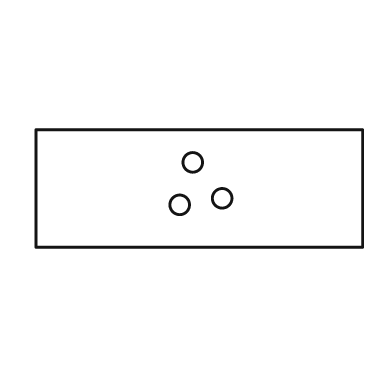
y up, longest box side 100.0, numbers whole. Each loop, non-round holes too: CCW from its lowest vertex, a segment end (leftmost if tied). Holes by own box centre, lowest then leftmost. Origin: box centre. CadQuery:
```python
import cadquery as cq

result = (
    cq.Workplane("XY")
    .moveTo(-50.0, -18.0)
    .lineTo(50.0, -18.0)
    .lineTo(50.0, 18.0)
    .lineTo(-50.0, 18.0)
    .close()
    .moveTo(-6.0, -5.0)
    .circle(3.0)
    .moveTo(7.0, -3.0)
    .circle(3.0)
    .moveTo(-2.0, 8.0)
    .circle(3.0)
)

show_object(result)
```